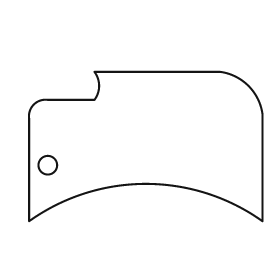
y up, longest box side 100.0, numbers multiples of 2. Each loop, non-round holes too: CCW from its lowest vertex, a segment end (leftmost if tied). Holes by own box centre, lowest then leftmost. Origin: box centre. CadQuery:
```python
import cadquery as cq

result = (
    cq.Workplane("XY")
    .moveTo(-50.0, -32.0)
    .threePointArc((0.0, -16.0), (50.0, -32.0))
    .lineTo(50.0, 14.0)
    .threePointArc((44.0, 26.0), (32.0, 32.0))
    .lineTo(-22.0, 32.0)
    .threePointArc((-20.0, 26.0), (-22.0, 20.0))
    .lineTo(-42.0, 20.0)
    .threePointArc((-48.0, 18.0), (-50.0, 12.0))
    .close()
    .moveTo(-42.0, -8.0)
    .circle(4.0)
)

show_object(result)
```